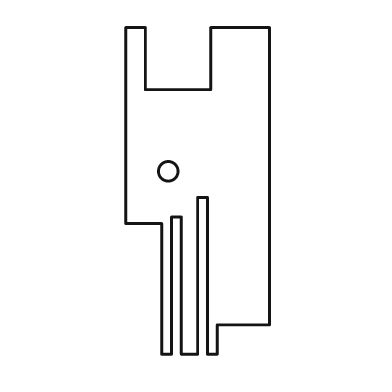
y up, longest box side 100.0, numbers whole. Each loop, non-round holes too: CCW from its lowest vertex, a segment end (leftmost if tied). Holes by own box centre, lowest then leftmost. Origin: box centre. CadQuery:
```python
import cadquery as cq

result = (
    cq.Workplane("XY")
    .moveTo(-11.0, -50.0)
    .lineTo(-8.0, -50.0)
    .lineTo(-8.0, -8.0)
    .lineTo(-5.0, -8.0)
    .lineTo(-5.0, -50.0)
    .lineTo(0.0, -50.0)
    .lineTo(0.0, -2.0)
    .lineTo(3.0, -2.0)
    .lineTo(3.0, -50.0)
    .lineTo(6.0, -50.0)
    .lineTo(6.0, -41.0)
    .lineTo(22.0, -41.0)
    .lineTo(22.0, 50.0)
    .lineTo(4.0, 50.0)
    .lineTo(4.0, 31.0)
    .lineTo(-16.0, 31.0)
    .lineTo(-16.0, 50.0)
    .lineTo(-22.0, 50.0)
    .lineTo(-22.0, -10.0)
    .lineTo(-11.0, -10.0)
    .close()
    .moveTo(-9.0, 6.0)
    .circle(3.0)
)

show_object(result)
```